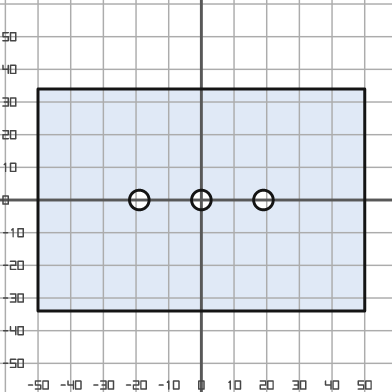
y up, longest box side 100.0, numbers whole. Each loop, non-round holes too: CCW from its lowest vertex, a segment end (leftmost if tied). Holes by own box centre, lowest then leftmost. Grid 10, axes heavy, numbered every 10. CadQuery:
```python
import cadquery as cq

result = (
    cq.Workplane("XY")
    .moveTo(-50.0, -34.0)
    .lineTo(50.0, -34.0)
    .lineTo(50.0, 34.0)
    .lineTo(-50.0, 34.0)
    .close()
    .moveTo(-19.0, 0.0)
    .circle(3.0)
    .moveTo(0.0, 0.0)
    .circle(3.0)
    .moveTo(19.0, 0.0)
    .circle(3.0)
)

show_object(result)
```